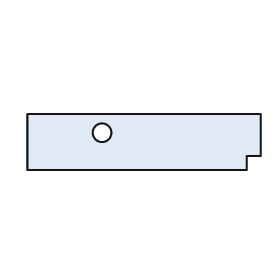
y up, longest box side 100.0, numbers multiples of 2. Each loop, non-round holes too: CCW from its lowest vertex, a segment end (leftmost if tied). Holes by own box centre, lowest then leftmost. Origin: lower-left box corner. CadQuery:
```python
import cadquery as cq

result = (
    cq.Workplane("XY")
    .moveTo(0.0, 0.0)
    .lineTo(94.0, 0.0)
    .lineTo(94.0, 6.0)
    .lineTo(100.0, 6.0)
    .lineTo(100.0, 24.0)
    .lineTo(0.0, 24.0)
    .close()
    .moveTo(32.0, 16.0)
    .circle(4.0)
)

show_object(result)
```